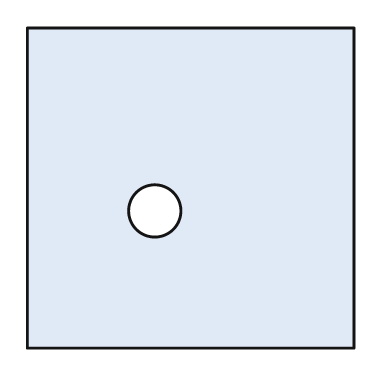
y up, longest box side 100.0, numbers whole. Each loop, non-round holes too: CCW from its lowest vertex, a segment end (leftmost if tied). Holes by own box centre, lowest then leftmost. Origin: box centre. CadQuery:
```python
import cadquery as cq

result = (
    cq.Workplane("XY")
    .moveTo(-50.0, -49.0)
    .lineTo(50.0, -49.0)
    .lineTo(50.0, 49.0)
    .lineTo(-50.0, 49.0)
    .close()
    .moveTo(-11.0, -7.0)
    .circle(8.0)
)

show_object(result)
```